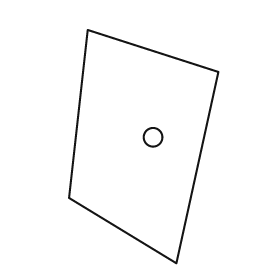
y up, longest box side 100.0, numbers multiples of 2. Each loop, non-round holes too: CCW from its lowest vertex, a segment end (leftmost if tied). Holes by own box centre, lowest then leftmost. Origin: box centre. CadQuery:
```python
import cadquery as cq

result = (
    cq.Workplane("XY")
    .moveTo(14.0, -50.0)
    .lineTo(32.0, 32.0)
    .lineTo(-24.0, 50.0)
    .lineTo(-32.0, -22.0)
    .close()
    .moveTo(4.0, 4.0)
    .circle(4.0)
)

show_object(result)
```